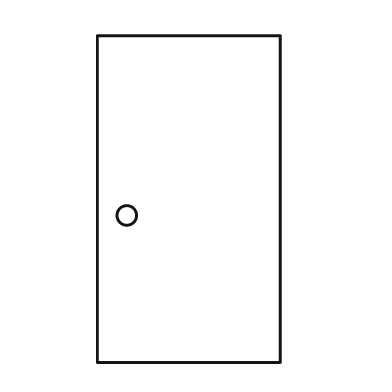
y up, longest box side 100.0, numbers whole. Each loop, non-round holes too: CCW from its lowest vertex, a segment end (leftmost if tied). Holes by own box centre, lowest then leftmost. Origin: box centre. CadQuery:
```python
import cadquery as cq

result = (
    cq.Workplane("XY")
    .moveTo(-28.0, -50.0)
    .lineTo(28.0, -50.0)
    .lineTo(28.0, 50.0)
    .lineTo(-28.0, 50.0)
    .close()
    .moveTo(-19.0, -5.0)
    .circle(3.0)
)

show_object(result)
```